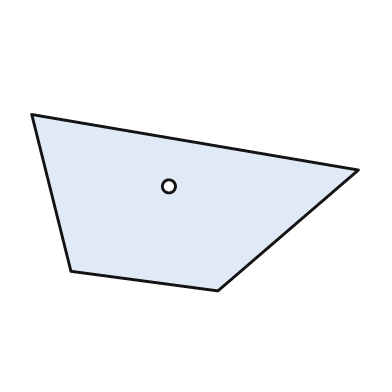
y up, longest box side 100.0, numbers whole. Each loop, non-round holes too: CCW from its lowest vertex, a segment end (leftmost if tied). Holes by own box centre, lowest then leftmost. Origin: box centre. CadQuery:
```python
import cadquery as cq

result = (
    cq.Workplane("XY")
    .moveTo(7.0, -27.0)
    .lineTo(50.0, 10.0)
    .lineTo(-50.0, 27.0)
    .lineTo(-38.0, -21.0)
    .close()
    .moveTo(-8.0, 5.0)
    .circle(2.0)
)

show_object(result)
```